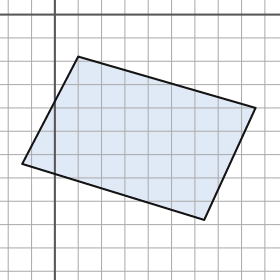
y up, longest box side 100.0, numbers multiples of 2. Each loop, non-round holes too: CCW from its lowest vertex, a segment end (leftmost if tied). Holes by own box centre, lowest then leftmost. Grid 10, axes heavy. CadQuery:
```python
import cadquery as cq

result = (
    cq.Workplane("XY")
    .moveTo(64.0, -88.0)
    .lineTo(86.0, -40.0)
    .lineTo(10.0, -18.0)
    .lineTo(-14.0, -64.0)
    .close()
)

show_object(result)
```